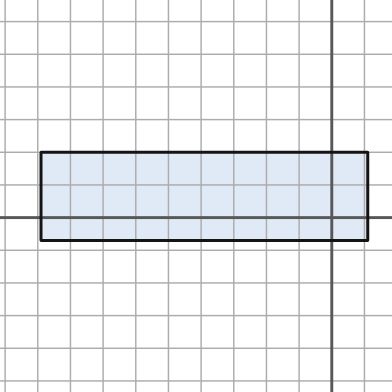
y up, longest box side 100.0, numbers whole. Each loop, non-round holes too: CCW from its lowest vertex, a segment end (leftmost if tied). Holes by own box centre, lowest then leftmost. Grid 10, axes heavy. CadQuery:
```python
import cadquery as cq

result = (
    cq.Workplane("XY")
    .moveTo(-89.0, -7.0)
    .lineTo(11.0, -7.0)
    .lineTo(11.0, 20.0)
    .lineTo(-89.0, 20.0)
    .close()
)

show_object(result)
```